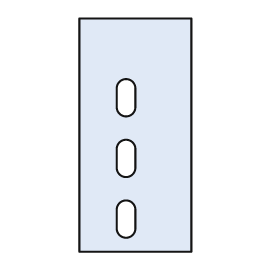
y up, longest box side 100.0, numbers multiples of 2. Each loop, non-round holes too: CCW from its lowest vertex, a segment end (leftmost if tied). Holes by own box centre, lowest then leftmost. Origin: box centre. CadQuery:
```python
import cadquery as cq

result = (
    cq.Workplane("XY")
    .moveTo(-24.0, -50.0)
    .lineTo(24.0, -50.0)
    .lineTo(24.0, 50.0)
    .lineTo(-24.0, 50.0)
    .close()
    .moveTo(-8.0, -40.0)
    .threePointArc((-4.0, -44.0), (0.0, -40.0))
    .lineTo(0.0, -32.0)
    .threePointArc((-4.0, -28.0), (-8.0, -32.0))
    .close()
    .moveTo(-8.0, -14.0)
    .threePointArc((-4.0, -18.0), (0.0, -14.0))
    .lineTo(0.0, -6.0)
    .threePointArc((-4.0, -2.0), (-8.0, -6.0))
    .close()
    .moveTo(-8.0, 12.0)
    .threePointArc((-4.0, 8.0), (0.0, 12.0))
    .lineTo(0.0, 20.0)
    .threePointArc((-4.0, 24.0), (-8.0, 20.0))
    .close()
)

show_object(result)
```